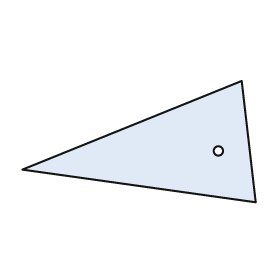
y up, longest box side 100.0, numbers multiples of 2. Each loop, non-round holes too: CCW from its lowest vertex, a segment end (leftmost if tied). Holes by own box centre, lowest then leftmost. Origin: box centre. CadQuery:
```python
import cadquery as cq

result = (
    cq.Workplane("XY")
    .moveTo(50.0, -26.0)
    .lineTo(44.0, 26.0)
    .lineTo(-50.0, -12.0)
    .close()
    .moveTo(34.0, -4.0)
    .circle(2.0)
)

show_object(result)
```